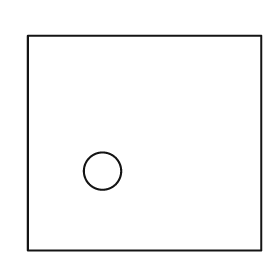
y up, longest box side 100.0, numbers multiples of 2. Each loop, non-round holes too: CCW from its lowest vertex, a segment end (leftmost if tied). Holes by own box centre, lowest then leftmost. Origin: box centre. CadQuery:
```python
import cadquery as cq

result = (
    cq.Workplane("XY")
    .moveTo(-50.0, -46.0)
    .lineTo(50.0, -46.0)
    .lineTo(50.0, 46.0)
    .lineTo(-50.0, 46.0)
    .close()
    .moveTo(-18.0, -12.0)
    .circle(8.0)
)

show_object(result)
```